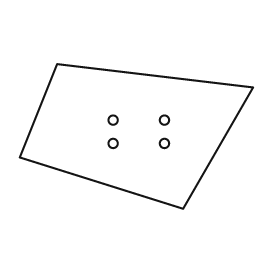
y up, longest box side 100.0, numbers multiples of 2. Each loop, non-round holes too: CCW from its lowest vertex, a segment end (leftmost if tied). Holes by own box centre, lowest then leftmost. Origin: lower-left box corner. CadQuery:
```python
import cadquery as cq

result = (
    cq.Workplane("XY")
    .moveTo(70.0, 0.0)
    .lineTo(100.0, 52.0)
    .lineTo(16.0, 62.0)
    .lineTo(0.0, 22.0)
    .close()
    .moveTo(40.0, 28.0)
    .circle(2.0)
    .moveTo(62.0, 28.0)
    .circle(2.0)
    .moveTo(40.0, 38.0)
    .circle(2.0)
    .moveTo(62.0, 38.0)
    .circle(2.0)
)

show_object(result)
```